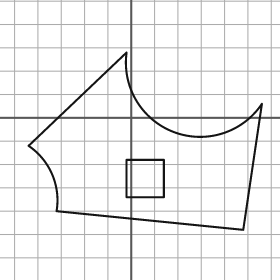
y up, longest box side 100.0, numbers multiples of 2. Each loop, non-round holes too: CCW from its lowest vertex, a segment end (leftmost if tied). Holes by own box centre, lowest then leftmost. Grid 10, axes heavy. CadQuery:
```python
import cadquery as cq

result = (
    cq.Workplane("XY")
    .moveTo(48.0, -48.0)
    .lineTo(56.0, 6.0)
    .threePointArc((18.0, -6.0), (-2.0, 28.0))
    .lineTo(-44.0, -12.0)
    .threePointArc((-34.0, -24.0), (-32.0, -40.0))
    .close()
    .moveTo(-2.0, -34.0)
    .lineTo(14.0, -34.0)
    .lineTo(14.0, -18.0)
    .lineTo(-2.0, -18.0)
    .close()
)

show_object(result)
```